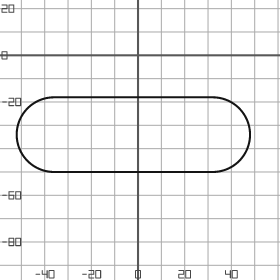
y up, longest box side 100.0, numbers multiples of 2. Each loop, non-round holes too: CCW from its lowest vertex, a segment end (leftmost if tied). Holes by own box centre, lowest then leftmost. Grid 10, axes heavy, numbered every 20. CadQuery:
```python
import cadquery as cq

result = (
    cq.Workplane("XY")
    .moveTo(-36.0, -50.0)
    .lineTo(32.0, -50.0)
    .threePointArc((48.0, -34.0), (32.0, -18.0))
    .lineTo(-36.0, -18.0)
    .threePointArc((-52.0, -34.0), (-36.0, -50.0))
    .close()
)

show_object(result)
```